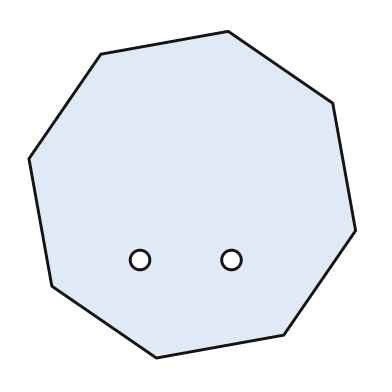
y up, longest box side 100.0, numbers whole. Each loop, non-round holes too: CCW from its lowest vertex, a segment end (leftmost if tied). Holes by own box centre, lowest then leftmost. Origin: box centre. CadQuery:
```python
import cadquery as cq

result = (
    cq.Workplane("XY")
    .moveTo(-11.0, -50.0)
    .lineTo(28.0, -43.0)
    .lineTo(50.0, -11.0)
    .lineTo(43.0, 28.0)
    .lineTo(11.0, 50.0)
    .lineTo(-28.0, 43.0)
    .lineTo(-50.0, 11.0)
    .lineTo(-43.0, -28.0)
    .close()
    .moveTo(-16.0, -20.0)
    .circle(3.0)
    .moveTo(12.0, -20.0)
    .circle(3.0)
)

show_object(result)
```